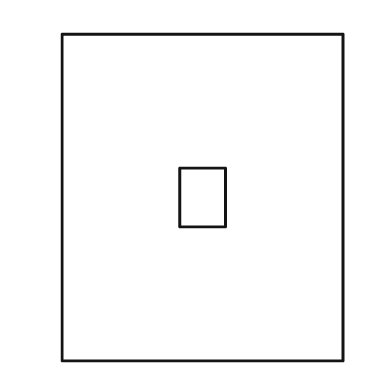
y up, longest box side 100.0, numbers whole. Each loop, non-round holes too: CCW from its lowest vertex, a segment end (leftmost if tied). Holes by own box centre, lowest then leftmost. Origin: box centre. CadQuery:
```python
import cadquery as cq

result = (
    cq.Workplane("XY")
    .moveTo(-43.0, -50.0)
    .lineTo(43.0, -50.0)
    .lineTo(43.0, 50.0)
    .lineTo(-43.0, 50.0)
    .close()
    .moveTo(-7.0, -9.0)
    .lineTo(7.0, -9.0)
    .lineTo(7.0, 9.0)
    .lineTo(-7.0, 9.0)
    .close()
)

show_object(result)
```